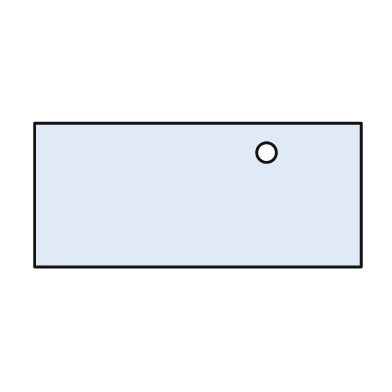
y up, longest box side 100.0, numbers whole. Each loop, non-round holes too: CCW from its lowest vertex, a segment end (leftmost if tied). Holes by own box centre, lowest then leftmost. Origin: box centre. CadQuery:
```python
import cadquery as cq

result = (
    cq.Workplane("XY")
    .moveTo(-50.0, -22.0)
    .lineTo(50.0, -22.0)
    .lineTo(50.0, 22.0)
    .lineTo(-50.0, 22.0)
    .close()
    .moveTo(21.0, 13.0)
    .circle(3.0)
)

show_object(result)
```